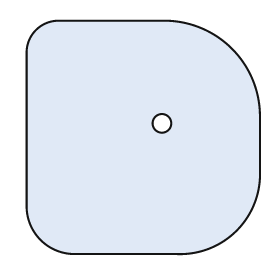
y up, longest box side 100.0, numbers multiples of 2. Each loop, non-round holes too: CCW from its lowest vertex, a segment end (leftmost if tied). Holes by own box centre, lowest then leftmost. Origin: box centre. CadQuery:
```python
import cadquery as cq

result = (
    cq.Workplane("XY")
    .moveTo(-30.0, -50.0)
    .lineTo(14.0, -50.0)
    .threePointArc((40.0, -40.0), (50.0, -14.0))
    .lineTo(50.0, 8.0)
    .threePointArc((38.0, 38.0), (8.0, 50.0))
    .lineTo(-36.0, 50.0)
    .threePointArc((-46.0, 46.0), (-50.0, 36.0))
    .lineTo(-50.0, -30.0)
    .threePointArc((-44.0, -44.0), (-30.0, -50.0))
    .close()
    .moveTo(8.0, 6.0)
    .circle(4.0)
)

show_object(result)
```